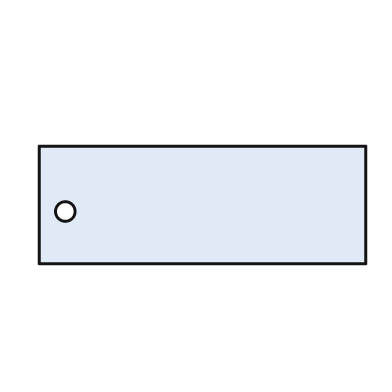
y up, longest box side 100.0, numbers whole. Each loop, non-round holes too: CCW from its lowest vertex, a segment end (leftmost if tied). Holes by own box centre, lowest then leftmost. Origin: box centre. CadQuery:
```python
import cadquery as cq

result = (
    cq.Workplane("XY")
    .moveTo(-50.0, -18.0)
    .lineTo(50.0, -18.0)
    .lineTo(50.0, 18.0)
    .lineTo(-50.0, 18.0)
    .close()
    .moveTo(-42.0, -2.0)
    .circle(3.0)
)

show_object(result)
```